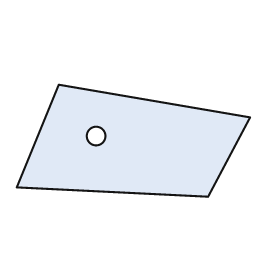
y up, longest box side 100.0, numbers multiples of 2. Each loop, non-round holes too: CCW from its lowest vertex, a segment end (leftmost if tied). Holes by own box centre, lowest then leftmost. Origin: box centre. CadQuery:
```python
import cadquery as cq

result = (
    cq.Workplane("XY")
    .moveTo(32.0, -24.0)
    .lineTo(50.0, 10.0)
    .lineTo(-32.0, 24.0)
    .lineTo(-50.0, -20.0)
    .close()
    .moveTo(-16.0, 2.0)
    .circle(4.0)
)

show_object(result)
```